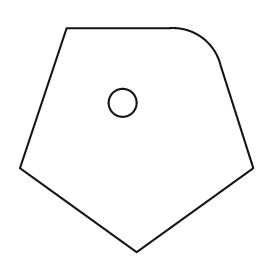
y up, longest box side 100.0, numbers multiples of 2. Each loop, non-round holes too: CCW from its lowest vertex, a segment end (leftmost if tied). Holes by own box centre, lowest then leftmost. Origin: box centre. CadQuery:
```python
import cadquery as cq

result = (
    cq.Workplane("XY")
    .moveTo(0.0, -48.0)
    .lineTo(50.0, -12.0)
    .lineTo(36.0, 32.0)
    .threePointArc((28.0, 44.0), (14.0, 48.0))
    .lineTo(-30.0, 48.0)
    .lineTo(-50.0, -12.0)
    .close()
    .moveTo(-6.0, 16.0)
    .circle(6.0)
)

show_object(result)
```